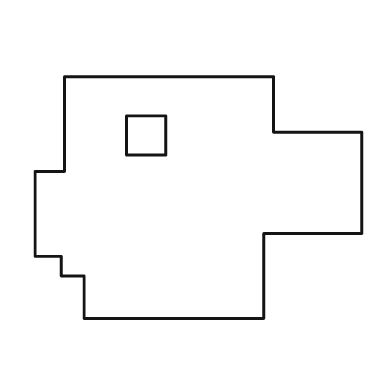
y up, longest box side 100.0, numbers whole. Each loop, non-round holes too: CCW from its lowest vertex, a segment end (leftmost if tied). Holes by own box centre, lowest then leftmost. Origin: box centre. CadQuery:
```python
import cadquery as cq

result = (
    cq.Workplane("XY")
    .moveTo(-35.0, -37.0)
    .lineTo(20.0, -37.0)
    .lineTo(20.0, -11.0)
    .lineTo(50.0, -11.0)
    .lineTo(50.0, 20.0)
    .lineTo(23.0, 20.0)
    .lineTo(23.0, 37.0)
    .lineTo(-41.0, 37.0)
    .lineTo(-41.0, 8.0)
    .lineTo(-50.0, 8.0)
    .lineTo(-50.0, -18.0)
    .lineTo(-42.0, -18.0)
    .lineTo(-42.0, -24.0)
    .lineTo(-35.0, -24.0)
    .close()
    .moveTo(-22.0, 13.0)
    .lineTo(-10.0, 13.0)
    .lineTo(-10.0, 25.0)
    .lineTo(-22.0, 25.0)
    .close()
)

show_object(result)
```